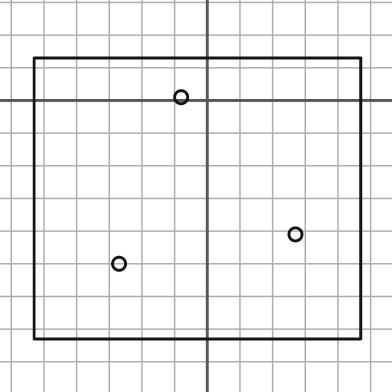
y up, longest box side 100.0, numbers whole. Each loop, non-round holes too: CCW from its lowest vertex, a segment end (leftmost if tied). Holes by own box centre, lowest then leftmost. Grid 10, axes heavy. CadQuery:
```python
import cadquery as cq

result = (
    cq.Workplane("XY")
    .moveTo(-53.0, -73.0)
    .lineTo(47.0, -73.0)
    .lineTo(47.0, 13.0)
    .lineTo(-53.0, 13.0)
    .close()
    .moveTo(-27.0, -50.0)
    .circle(2.0)
    .moveTo(27.0, -41.0)
    .circle(2.0)
    .moveTo(-8.0, 1.0)
    .circle(2.0)
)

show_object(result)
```